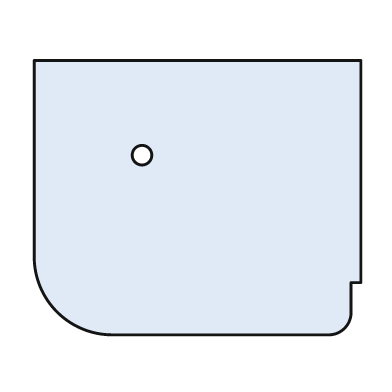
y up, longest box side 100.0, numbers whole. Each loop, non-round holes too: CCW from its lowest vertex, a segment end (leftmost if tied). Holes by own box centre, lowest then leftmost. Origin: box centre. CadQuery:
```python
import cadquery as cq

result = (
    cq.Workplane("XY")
    .moveTo(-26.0, -42.0)
    .lineTo(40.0, -42.0)
    .threePointArc((45.0, -40.0), (47.0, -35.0))
    .lineTo(47.0, -26.0)
    .lineTo(50.0, -26.0)
    .lineTo(50.0, 42.0)
    .lineTo(-50.0, 42.0)
    .lineTo(-50.0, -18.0)
    .threePointArc((-43.0, -35.0), (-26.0, -42.0))
    .close()
    .moveTo(-17.0, 13.0)
    .circle(3.0)
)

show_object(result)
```